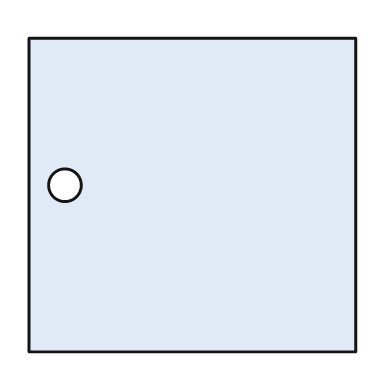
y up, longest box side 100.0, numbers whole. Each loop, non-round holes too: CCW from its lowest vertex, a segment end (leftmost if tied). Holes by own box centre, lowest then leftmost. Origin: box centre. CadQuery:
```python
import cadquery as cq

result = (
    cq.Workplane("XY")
    .moveTo(-50.0, -48.0)
    .lineTo(50.0, -48.0)
    .lineTo(50.0, 48.0)
    .lineTo(-50.0, 48.0)
    .close()
    .moveTo(-39.0, 3.0)
    .circle(5.0)
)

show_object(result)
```